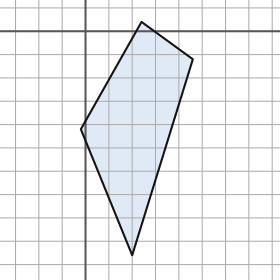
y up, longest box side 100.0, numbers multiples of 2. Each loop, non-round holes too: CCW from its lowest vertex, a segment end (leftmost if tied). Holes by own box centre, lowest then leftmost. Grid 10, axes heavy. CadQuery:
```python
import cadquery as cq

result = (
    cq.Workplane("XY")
    .moveTo(20.0, -96.0)
    .lineTo(46.0, -12.0)
    .lineTo(24.0, 4.0)
    .lineTo(-2.0, -42.0)
    .close()
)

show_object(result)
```